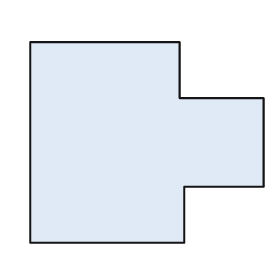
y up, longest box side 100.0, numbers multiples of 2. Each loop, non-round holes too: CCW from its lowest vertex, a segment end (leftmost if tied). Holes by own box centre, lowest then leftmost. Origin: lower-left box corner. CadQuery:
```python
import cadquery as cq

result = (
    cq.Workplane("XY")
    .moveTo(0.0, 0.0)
    .lineTo(66.0, 0.0)
    .lineTo(66.0, 24.0)
    .lineTo(100.0, 24.0)
    .lineTo(100.0, 62.0)
    .lineTo(64.0, 62.0)
    .lineTo(64.0, 86.0)
    .lineTo(0.0, 86.0)
    .close()
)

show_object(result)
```